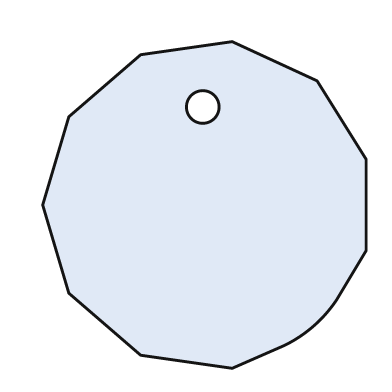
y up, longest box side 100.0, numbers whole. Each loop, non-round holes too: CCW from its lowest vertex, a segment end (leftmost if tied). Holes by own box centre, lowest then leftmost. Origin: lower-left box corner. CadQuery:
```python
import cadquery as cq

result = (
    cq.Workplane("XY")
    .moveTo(58.0, 0.0)
    .lineTo(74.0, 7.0)
    .threePointArc((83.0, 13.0), (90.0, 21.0))
    .lineTo(99.0, 36.0)
    .lineTo(99.0, 64.0)
    .lineTo(84.0, 88.0)
    .lineTo(58.0, 100.0)
    .lineTo(30.0, 96.0)
    .lineTo(8.0, 77.0)
    .lineTo(0.0, 50.0)
    .lineTo(8.0, 23.0)
    .lineTo(30.0, 4.0)
    .close()
    .moveTo(49.0, 80.0)
    .circle(5.0)
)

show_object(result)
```